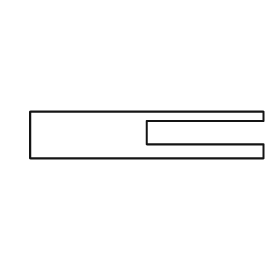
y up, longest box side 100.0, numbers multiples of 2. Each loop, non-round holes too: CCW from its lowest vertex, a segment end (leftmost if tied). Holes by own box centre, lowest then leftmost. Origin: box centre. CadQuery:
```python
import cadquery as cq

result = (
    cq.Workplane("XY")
    .moveTo(-50.0, -10.0)
    .lineTo(50.0, -10.0)
    .lineTo(50.0, -4.0)
    .lineTo(0.0, -4.0)
    .lineTo(0.0, 6.0)
    .lineTo(50.0, 6.0)
    .lineTo(50.0, 10.0)
    .lineTo(-50.0, 10.0)
    .close()
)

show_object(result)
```